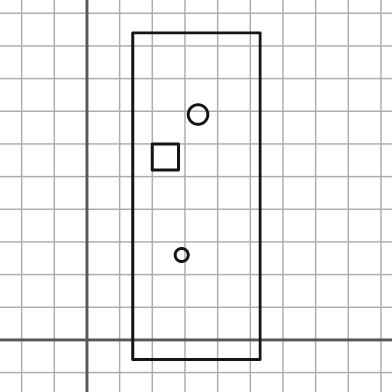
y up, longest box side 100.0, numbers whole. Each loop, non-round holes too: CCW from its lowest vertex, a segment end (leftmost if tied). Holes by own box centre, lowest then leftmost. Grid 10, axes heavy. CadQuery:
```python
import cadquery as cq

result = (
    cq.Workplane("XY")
    .moveTo(14.0, -6.0)
    .lineTo(53.0, -6.0)
    .lineTo(53.0, 94.0)
    .lineTo(14.0, 94.0)
    .close()
    .moveTo(29.0, 26.0)
    .circle(2.0)
    .moveTo(20.0, 52.0)
    .lineTo(28.0, 52.0)
    .lineTo(28.0, 60.0)
    .lineTo(20.0, 60.0)
    .close()
    .moveTo(34.0, 69.0)
    .circle(3.0)
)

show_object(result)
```